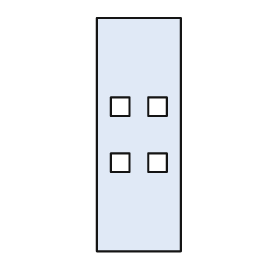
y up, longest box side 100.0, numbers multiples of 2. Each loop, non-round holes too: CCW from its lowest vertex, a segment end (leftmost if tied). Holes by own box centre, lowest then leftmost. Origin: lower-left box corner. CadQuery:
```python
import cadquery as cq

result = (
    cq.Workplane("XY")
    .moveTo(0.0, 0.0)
    .lineTo(36.0, 0.0)
    .lineTo(36.0, 100.0)
    .lineTo(0.0, 100.0)
    .close()
    .moveTo(6.0, 34.0)
    .lineTo(14.0, 34.0)
    .lineTo(14.0, 42.0)
    .lineTo(6.0, 42.0)
    .close()
    .moveTo(22.0, 34.0)
    .lineTo(30.0, 34.0)
    .lineTo(30.0, 42.0)
    .lineTo(22.0, 42.0)
    .close()
    .moveTo(6.0, 58.0)
    .lineTo(14.0, 58.0)
    .lineTo(14.0, 66.0)
    .lineTo(6.0, 66.0)
    .close()
    .moveTo(22.0, 58.0)
    .lineTo(30.0, 58.0)
    .lineTo(30.0, 66.0)
    .lineTo(22.0, 66.0)
    .close()
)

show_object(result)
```